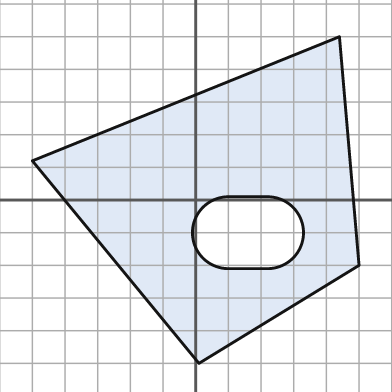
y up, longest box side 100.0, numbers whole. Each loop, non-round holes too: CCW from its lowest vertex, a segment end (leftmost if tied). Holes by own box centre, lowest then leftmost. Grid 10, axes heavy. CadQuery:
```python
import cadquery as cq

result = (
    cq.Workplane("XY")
    .moveTo(1.0, -50.0)
    .lineTo(50.0, -20.0)
    .lineTo(44.0, 50.0)
    .lineTo(-50.0, 12.0)
    .close()
    .moveTo(10.0, -21.0)
    .lineTo(22.0, -21.0)
    .threePointArc((33.0, -10.0), (22.0, 1.0))
    .lineTo(10.0, 1.0)
    .threePointArc((-1.0, -10.0), (10.0, -21.0))
    .close()
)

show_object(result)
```